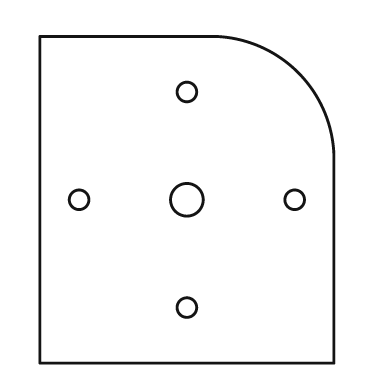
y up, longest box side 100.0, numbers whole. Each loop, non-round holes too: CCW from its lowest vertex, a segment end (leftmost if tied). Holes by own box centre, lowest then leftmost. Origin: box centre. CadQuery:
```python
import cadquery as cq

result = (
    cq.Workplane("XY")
    .moveTo(-45.0, -50.0)
    .lineTo(45.0, -50.0)
    .lineTo(45.0, 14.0)
    .threePointArc((34.0, 39.0), (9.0, 50.0))
    .lineTo(-45.0, 50.0)
    .close()
    .moveTo(0.0, -33.0)
    .circle(3.0)
    .moveTo(-33.0, 0.0)
    .circle(3.0)
    .moveTo(0.0, 0.0)
    .circle(5.0)
    .moveTo(33.0, 0.0)
    .circle(3.0)
    .moveTo(0.0, 33.0)
    .circle(3.0)
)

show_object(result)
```